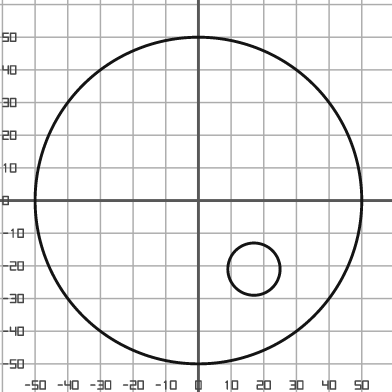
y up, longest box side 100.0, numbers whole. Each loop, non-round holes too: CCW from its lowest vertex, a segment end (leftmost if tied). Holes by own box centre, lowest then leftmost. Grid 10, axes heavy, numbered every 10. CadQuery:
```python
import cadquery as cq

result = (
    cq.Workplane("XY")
    .moveTo(0.0, 0.0)
    .circle(50.0)
    .moveTo(17.0, -21.0)
    .circle(8.0)
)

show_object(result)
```